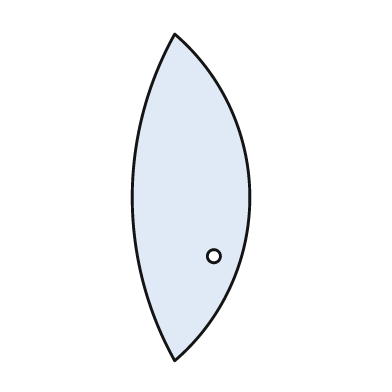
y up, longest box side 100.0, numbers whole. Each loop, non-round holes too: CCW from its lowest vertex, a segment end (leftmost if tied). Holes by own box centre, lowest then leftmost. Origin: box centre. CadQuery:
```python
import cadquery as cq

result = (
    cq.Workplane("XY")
    .moveTo(-5.0, -50.0)
    .threePointArc((18.0, 0.0), (-5.0, 50.0))
    .threePointArc((-18.0, 0.0), (-5.0, -50.0))
    .close()
    .moveTo(7.0, -18.0)
    .circle(2.0)
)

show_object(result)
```